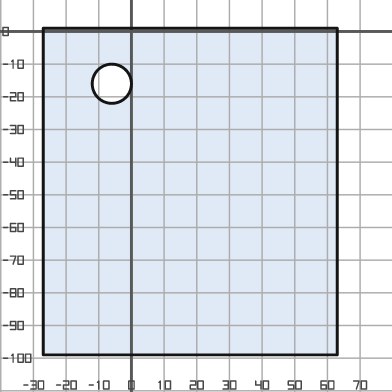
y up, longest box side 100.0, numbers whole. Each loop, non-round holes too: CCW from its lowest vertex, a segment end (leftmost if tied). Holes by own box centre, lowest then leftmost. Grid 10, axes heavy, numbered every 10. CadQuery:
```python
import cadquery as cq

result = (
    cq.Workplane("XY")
    .moveTo(-27.0, -99.0)
    .lineTo(63.0, -99.0)
    .lineTo(63.0, 1.0)
    .lineTo(-27.0, 1.0)
    .close()
    .moveTo(-6.0, -16.0)
    .circle(6.0)
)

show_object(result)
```